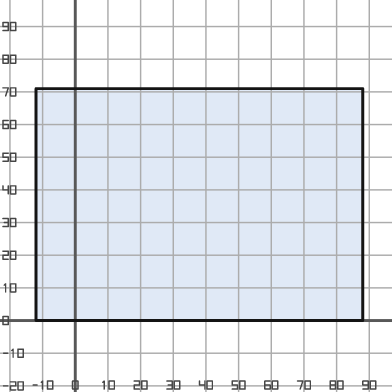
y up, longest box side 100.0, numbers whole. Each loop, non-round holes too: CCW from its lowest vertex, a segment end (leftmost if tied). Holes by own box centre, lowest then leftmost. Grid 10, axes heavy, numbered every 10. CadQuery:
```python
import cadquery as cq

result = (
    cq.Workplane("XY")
    .moveTo(-12.0, 0.0)
    .lineTo(88.0, 0.0)
    .lineTo(88.0, 71.0)
    .lineTo(-12.0, 71.0)
    .close()
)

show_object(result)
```